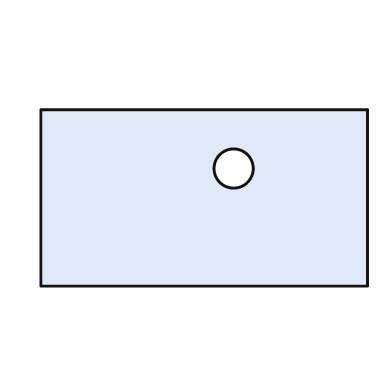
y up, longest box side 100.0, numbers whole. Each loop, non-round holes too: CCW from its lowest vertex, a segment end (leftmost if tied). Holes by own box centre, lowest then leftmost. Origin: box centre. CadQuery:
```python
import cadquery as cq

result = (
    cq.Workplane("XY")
    .moveTo(-50.0, -27.0)
    .lineTo(50.0, -27.0)
    .lineTo(50.0, 27.0)
    .lineTo(-50.0, 27.0)
    .close()
    .moveTo(9.0, 9.0)
    .circle(6.0)
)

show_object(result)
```